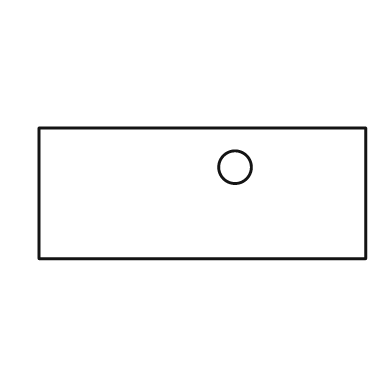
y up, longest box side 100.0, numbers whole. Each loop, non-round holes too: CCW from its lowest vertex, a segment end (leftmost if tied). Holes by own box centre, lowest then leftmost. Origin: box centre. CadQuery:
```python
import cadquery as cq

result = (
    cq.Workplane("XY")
    .moveTo(-50.0, -20.0)
    .lineTo(50.0, -20.0)
    .lineTo(50.0, 20.0)
    .lineTo(-50.0, 20.0)
    .close()
    .moveTo(10.0, 8.0)
    .circle(5.0)
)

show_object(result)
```